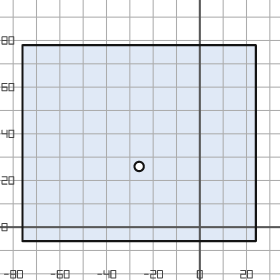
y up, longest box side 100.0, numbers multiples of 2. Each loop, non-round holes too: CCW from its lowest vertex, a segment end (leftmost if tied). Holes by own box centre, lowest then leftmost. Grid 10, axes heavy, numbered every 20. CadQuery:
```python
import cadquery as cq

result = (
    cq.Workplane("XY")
    .moveTo(-76.0, -6.0)
    .lineTo(24.0, -6.0)
    .lineTo(24.0, 78.0)
    .lineTo(-76.0, 78.0)
    .close()
    .moveTo(-26.0, 26.0)
    .circle(2.0)
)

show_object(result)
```